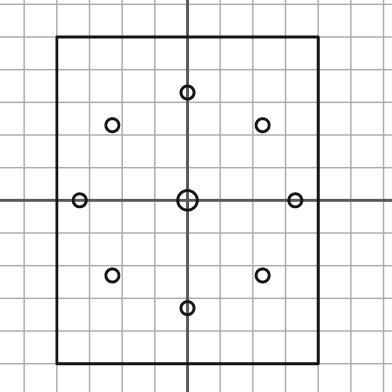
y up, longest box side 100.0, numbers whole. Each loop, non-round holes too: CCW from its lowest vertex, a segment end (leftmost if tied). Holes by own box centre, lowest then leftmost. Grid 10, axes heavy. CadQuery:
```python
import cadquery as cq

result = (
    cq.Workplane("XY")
    .moveTo(-40.0, -50.0)
    .lineTo(40.0, -50.0)
    .lineTo(40.0, 50.0)
    .lineTo(-40.0, 50.0)
    .close()
    .moveTo(0.0, -33.0)
    .circle(2.0)
    .moveTo(-23.0, -23.0)
    .circle(2.0)
    .moveTo(23.0, -23.0)
    .circle(2.0)
    .moveTo(-33.0, 0.0)
    .circle(2.0)
    .moveTo(0.0, 0.0)
    .circle(3.0)
    .moveTo(33.0, 0.0)
    .circle(2.0)
    .moveTo(-23.0, 23.0)
    .circle(2.0)
    .moveTo(23.0, 23.0)
    .circle(2.0)
    .moveTo(0.0, 33.0)
    .circle(2.0)
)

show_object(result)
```